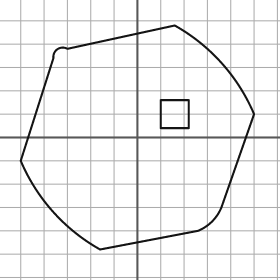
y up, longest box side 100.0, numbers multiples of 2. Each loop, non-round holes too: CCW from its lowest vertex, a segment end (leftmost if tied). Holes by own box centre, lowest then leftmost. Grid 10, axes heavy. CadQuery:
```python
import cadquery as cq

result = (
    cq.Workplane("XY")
    .moveTo(-16.0, -48.0)
    .lineTo(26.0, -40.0)
    .threePointArc((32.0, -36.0), (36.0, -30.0))
    .lineTo(50.0, 10.0)
    .threePointArc((36.0, 32.0), (16.0, 48.0))
    .lineTo(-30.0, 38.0)
    .threePointArc((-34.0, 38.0), (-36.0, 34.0))
    .lineTo(-50.0, -10.0)
    .threePointArc((-36.0, -32.0), (-16.0, -48.0))
    .close()
    .moveTo(10.0, 4.0)
    .lineTo(22.0, 4.0)
    .lineTo(22.0, 16.0)
    .lineTo(10.0, 16.0)
    .close()
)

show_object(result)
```